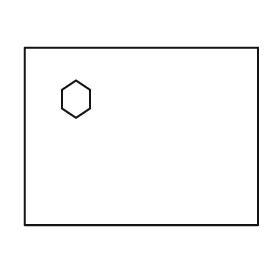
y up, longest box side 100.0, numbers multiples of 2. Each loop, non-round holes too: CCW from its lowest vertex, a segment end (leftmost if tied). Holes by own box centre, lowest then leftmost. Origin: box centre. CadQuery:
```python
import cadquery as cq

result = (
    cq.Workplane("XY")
    .moveTo(-50.0, -38.0)
    .lineTo(50.0, -38.0)
    .lineTo(50.0, 38.0)
    .lineTo(-50.0, 38.0)
    .close()
    .moveTo(-28.0, 8.0)
    .lineTo(-22.0, 12.0)
    .lineTo(-22.0, 20.0)
    .lineTo(-28.0, 24.0)
    .lineTo(-34.0, 20.0)
    .lineTo(-34.0, 12.0)
    .close()
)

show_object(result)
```